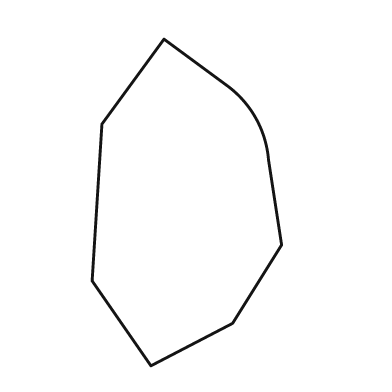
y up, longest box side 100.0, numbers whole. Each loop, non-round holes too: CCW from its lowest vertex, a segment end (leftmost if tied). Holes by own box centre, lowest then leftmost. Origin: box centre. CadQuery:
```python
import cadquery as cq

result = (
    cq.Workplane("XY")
    .moveTo(-11.0, -50.0)
    .lineTo(14.0, -37.0)
    .lineTo(29.0, -13.0)
    .lineTo(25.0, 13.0)
    .threePointArc((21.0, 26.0), (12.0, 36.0))
    .lineTo(-7.0, 50.0)
    .lineTo(-26.0, 24.0)
    .lineTo(-29.0, -24.0)
    .close()
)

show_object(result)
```